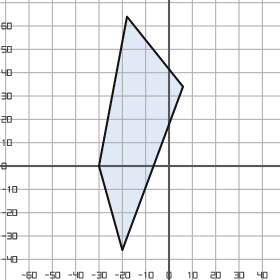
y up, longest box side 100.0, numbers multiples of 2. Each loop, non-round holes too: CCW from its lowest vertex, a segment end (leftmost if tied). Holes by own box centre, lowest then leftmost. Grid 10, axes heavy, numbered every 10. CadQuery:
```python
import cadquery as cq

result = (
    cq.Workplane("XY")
    .moveTo(-20.0, -36.0)
    .lineTo(6.0, 34.0)
    .lineTo(-18.0, 64.0)
    .lineTo(-30.0, 0.0)
    .close()
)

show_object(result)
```